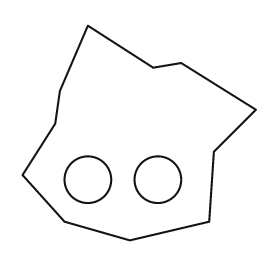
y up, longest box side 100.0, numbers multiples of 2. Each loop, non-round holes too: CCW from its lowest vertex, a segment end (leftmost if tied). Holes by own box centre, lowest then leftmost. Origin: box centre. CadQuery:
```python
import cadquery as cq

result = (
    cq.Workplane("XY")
    .moveTo(-4.0, -46.0)
    .lineTo(30.0, -38.0)
    .lineTo(32.0, -8.0)
    .lineTo(50.0, 10.0)
    .lineTo(18.0, 30.0)
    .lineTo(6.0, 28.0)
    .lineTo(-22.0, 46.0)
    .lineTo(-34.0, 18.0)
    .lineTo(-36.0, 4.0)
    .lineTo(-50.0, -18.0)
    .lineTo(-32.0, -38.0)
    .close()
    .moveTo(-22.0, -20.0)
    .circle(10.0)
    .moveTo(8.0, -20.0)
    .circle(10.0)
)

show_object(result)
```